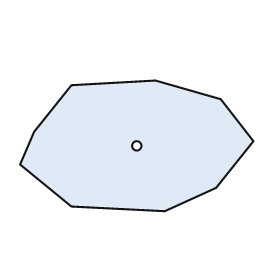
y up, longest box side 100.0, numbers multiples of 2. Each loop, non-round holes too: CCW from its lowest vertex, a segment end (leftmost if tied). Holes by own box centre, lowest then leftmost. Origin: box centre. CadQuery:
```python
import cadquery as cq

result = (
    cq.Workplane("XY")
    .moveTo(12.0, -28.0)
    .lineTo(34.0, -18.0)
    .lineTo(50.0, 2.0)
    .lineTo(36.0, 20.0)
    .lineTo(8.0, 28.0)
    .lineTo(-28.0, 26.0)
    .lineTo(-44.0, 6.0)
    .lineTo(-50.0, -8.0)
    .lineTo(-28.0, -26.0)
    .close()
    .moveTo(0.0, 0.0)
    .circle(2.0)
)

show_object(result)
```